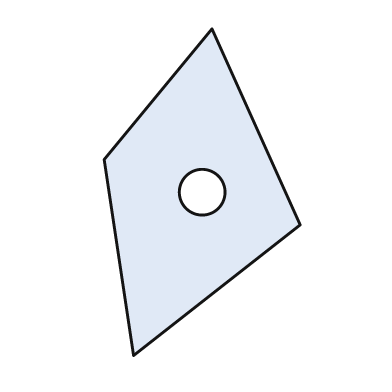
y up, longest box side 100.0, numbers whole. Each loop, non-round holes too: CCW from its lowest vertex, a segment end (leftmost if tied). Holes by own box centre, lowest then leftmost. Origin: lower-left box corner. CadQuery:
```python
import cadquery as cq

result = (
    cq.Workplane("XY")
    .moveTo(9.0, 0.0)
    .lineTo(60.0, 40.0)
    .lineTo(33.0, 100.0)
    .lineTo(0.0, 60.0)
    .close()
    .moveTo(30.0, 50.0)
    .circle(7.0)
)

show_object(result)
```